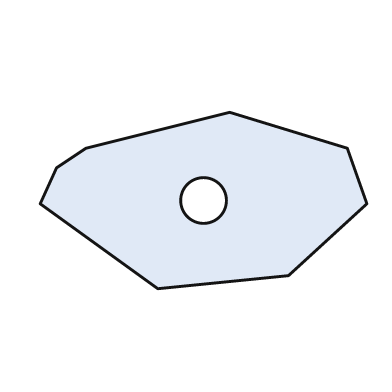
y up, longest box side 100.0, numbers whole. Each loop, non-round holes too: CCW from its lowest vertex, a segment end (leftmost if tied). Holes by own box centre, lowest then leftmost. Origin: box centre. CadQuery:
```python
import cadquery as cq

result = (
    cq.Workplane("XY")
    .moveTo(-14.0, -27.0)
    .lineTo(26.0, -23.0)
    .lineTo(50.0, -1.0)
    .lineTo(44.0, 16.0)
    .lineTo(8.0, 27.0)
    .lineTo(-36.0, 16.0)
    .lineTo(-45.0, 10.0)
    .lineTo(-50.0, -1.0)
    .close()
    .moveTo(0.0, 0.0)
    .circle(7.0)
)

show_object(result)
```